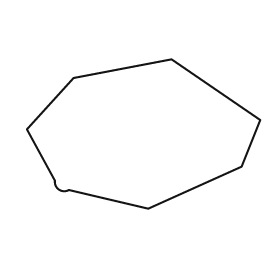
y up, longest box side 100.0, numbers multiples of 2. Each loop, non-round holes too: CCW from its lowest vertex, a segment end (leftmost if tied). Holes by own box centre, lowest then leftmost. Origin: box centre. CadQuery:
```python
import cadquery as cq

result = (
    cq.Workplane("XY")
    .moveTo(2.0, -32.0)
    .lineTo(42.0, -14.0)
    .lineTo(50.0, 6.0)
    .lineTo(12.0, 32.0)
    .lineTo(-30.0, 24.0)
    .lineTo(-50.0, 2.0)
    .lineTo(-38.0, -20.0)
    .threePointArc((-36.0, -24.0), (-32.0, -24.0))
    .close()
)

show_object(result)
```